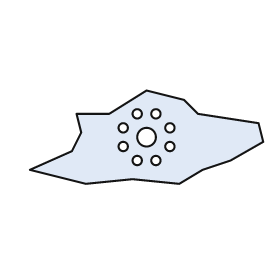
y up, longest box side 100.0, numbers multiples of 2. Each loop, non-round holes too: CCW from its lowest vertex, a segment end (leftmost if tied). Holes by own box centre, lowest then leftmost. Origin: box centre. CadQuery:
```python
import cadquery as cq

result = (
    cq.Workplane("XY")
    .moveTo(-26.0, -20.0)
    .lineTo(-6.0, -18.0)
    .lineTo(14.0, -20.0)
    .lineTo(24.0, -14.0)
    .lineTo(36.0, -10.0)
    .lineTo(50.0, -2.0)
    .lineTo(48.0, 6.0)
    .lineTo(22.0, 10.0)
    .lineTo(16.0, 16.0)
    .lineTo(0.0, 20.0)
    .lineTo(-16.0, 10.0)
    .lineTo(-30.0, 10.0)
    .lineTo(-28.0, 2.0)
    .lineTo(-32.0, -6.0)
    .lineTo(-50.0, -14.0)
    .close()
    .moveTo(-4.0, -10.0)
    .circle(2.0)
    .moveTo(4.0, -10.0)
    .circle(2.0)
    .moveTo(-10.0, -4.0)
    .circle(2.0)
    .moveTo(10.0, -4.0)
    .circle(2.0)
    .moveTo(0.0, 0.0)
    .circle(4.0)
    .moveTo(-10.0, 4.0)
    .circle(2.0)
    .moveTo(10.0, 4.0)
    .circle(2.0)
    .moveTo(-4.0, 10.0)
    .circle(2.0)
    .moveTo(4.0, 10.0)
    .circle(2.0)
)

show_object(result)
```